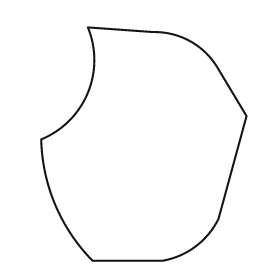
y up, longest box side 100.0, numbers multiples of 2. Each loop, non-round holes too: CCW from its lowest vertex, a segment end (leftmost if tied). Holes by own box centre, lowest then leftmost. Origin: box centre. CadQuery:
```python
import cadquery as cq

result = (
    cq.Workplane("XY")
    .moveTo(-22.0, -50.0)
    .lineTo(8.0, -50.0)
    .threePointArc((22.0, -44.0), (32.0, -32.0))
    .lineTo(44.0, 12.0)
    .lineTo(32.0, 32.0)
    .threePointArc((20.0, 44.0), (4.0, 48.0))
    .lineTo(-24.0, 50.0)
    .threePointArc((-24.0, 22.0), (-44.0, 2.0))
    .threePointArc((-38.0, -26.0), (-22.0, -50.0))
    .close()
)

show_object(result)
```